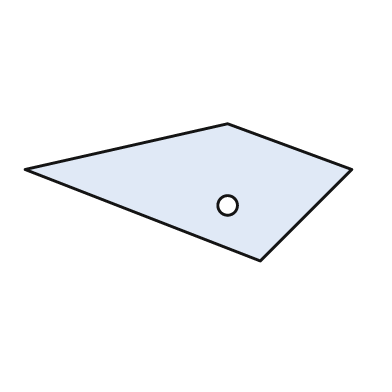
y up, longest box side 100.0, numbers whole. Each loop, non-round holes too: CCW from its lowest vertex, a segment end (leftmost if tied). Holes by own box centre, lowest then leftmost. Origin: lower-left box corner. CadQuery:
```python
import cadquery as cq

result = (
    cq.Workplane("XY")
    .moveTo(72.0, 0.0)
    .lineTo(100.0, 28.0)
    .lineTo(62.0, 42.0)
    .lineTo(0.0, 28.0)
    .close()
    .moveTo(62.0, 17.0)
    .circle(3.0)
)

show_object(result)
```